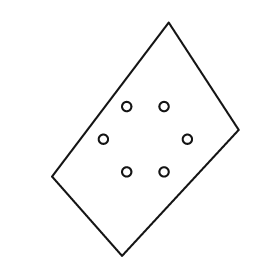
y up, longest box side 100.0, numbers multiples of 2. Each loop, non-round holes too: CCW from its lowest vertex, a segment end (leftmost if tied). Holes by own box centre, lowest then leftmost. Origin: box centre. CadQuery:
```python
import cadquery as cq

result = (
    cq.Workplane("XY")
    .moveTo(-10.0, -50.0)
    .lineTo(40.0, 4.0)
    .lineTo(10.0, 50.0)
    .lineTo(-40.0, -16.0)
    .close()
    .moveTo(-8.0, -14.0)
    .circle(2.0)
    .moveTo(8.0, -14.0)
    .circle(2.0)
    .moveTo(-18.0, 0.0)
    .circle(2.0)
    .moveTo(18.0, 0.0)
    .circle(2.0)
    .moveTo(-8.0, 14.0)
    .circle(2.0)
    .moveTo(8.0, 14.0)
    .circle(2.0)
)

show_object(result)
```